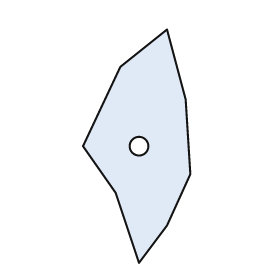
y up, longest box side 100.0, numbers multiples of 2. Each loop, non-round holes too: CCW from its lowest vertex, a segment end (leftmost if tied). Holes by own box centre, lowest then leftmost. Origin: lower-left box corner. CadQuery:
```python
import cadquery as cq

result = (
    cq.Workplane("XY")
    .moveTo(24.0, 0.0)
    .lineTo(36.0, 16.0)
    .lineTo(46.0, 38.0)
    .lineTo(44.0, 70.0)
    .lineTo(36.0, 100.0)
    .lineTo(16.0, 84.0)
    .lineTo(0.0, 50.0)
    .lineTo(14.0, 30.0)
    .close()
    .moveTo(24.0, 50.0)
    .circle(4.0)
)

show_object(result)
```